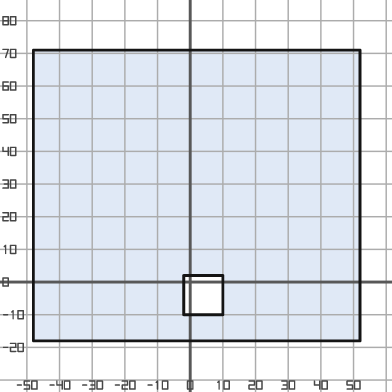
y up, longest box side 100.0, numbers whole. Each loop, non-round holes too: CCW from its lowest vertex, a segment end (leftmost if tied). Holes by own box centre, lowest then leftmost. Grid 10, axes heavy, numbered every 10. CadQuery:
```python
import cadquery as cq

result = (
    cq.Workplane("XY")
    .moveTo(-48.0, -18.0)
    .lineTo(52.0, -18.0)
    .lineTo(52.0, 71.0)
    .lineTo(-48.0, 71.0)
    .close()
    .moveTo(-2.0, -10.0)
    .lineTo(10.0, -10.0)
    .lineTo(10.0, 2.0)
    .lineTo(-2.0, 2.0)
    .close()
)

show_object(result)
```